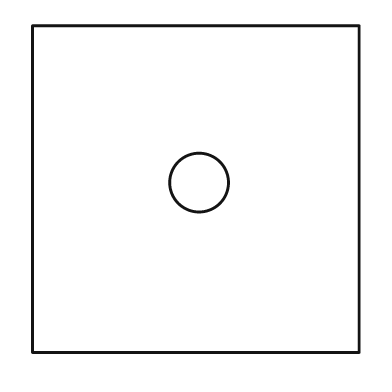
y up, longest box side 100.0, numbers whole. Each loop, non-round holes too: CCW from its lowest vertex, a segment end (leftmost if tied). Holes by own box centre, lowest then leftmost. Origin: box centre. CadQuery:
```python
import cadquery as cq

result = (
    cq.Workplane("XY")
    .moveTo(-50.0, -50.0)
    .lineTo(50.0, -50.0)
    .lineTo(50.0, 50.0)
    .lineTo(-50.0, 50.0)
    .close()
    .moveTo(1.0, 2.0)
    .circle(9.0)
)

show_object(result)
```